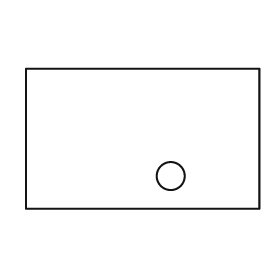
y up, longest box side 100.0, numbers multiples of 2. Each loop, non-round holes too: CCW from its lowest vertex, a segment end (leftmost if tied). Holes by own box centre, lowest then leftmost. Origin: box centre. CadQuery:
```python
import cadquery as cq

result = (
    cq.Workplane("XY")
    .moveTo(-50.0, -30.0)
    .lineTo(50.0, -30.0)
    .lineTo(50.0, 30.0)
    .lineTo(-50.0, 30.0)
    .close()
    .moveTo(12.0, -16.0)
    .circle(6.0)
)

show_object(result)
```